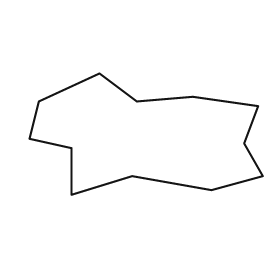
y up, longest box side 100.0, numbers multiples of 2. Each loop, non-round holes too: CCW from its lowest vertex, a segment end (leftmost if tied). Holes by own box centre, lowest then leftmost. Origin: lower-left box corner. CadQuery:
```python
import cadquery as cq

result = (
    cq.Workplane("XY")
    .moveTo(18.0, 0.0)
    .lineTo(44.0, 8.0)
    .lineTo(78.0, 2.0)
    .lineTo(100.0, 8.0)
    .lineTo(92.0, 22.0)
    .lineTo(98.0, 38.0)
    .lineTo(70.0, 42.0)
    .lineTo(46.0, 40.0)
    .lineTo(30.0, 52.0)
    .lineTo(4.0, 40.0)
    .lineTo(0.0, 24.0)
    .lineTo(18.0, 20.0)
    .close()
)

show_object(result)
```